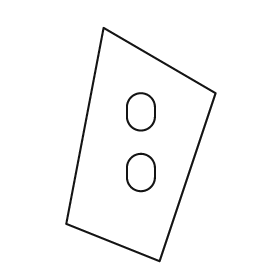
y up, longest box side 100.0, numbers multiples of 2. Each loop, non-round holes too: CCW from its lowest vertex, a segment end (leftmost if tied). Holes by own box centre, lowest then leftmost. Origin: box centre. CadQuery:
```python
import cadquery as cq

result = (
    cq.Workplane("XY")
    .moveTo(8.0, -50.0)
    .lineTo(32.0, 22.0)
    .lineTo(-16.0, 50.0)
    .lineTo(-32.0, -34.0)
    .close()
    .moveTo(-6.0, -14.0)
    .threePointArc((0.0, -20.0), (6.0, -14.0))
    .lineTo(6.0, -10.0)
    .threePointArc((0.0, -4.0), (-6.0, -10.0))
    .close()
    .moveTo(-6.0, 12.0)
    .threePointArc((0.0, 6.0), (6.0, 12.0))
    .lineTo(6.0, 16.0)
    .threePointArc((0.0, 22.0), (-6.0, 16.0))
    .close()
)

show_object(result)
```